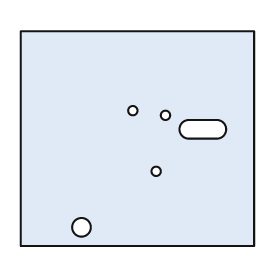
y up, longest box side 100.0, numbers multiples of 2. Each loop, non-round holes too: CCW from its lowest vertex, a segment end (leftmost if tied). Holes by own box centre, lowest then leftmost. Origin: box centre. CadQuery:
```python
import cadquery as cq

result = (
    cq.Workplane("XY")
    .moveTo(-50.0, -46.0)
    .lineTo(50.0, -46.0)
    .lineTo(50.0, 46.0)
    .lineTo(-50.0, 46.0)
    .close()
    .moveTo(-24.0, -38.0)
    .circle(4.0)
    .moveTo(8.0, -14.0)
    .circle(2.0)
    .moveTo(22.0, 0.0)
    .lineTo(34.0, 0.0)
    .threePointArc((38.0, 4.0), (34.0, 8.0))
    .lineTo(22.0, 8.0)
    .threePointArc((18.0, 4.0), (22.0, 0.0))
    .close()
    .moveTo(12.0, 10.0)
    .circle(2.0)
    .moveTo(-2.0, 12.0)
    .circle(2.0)
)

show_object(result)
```